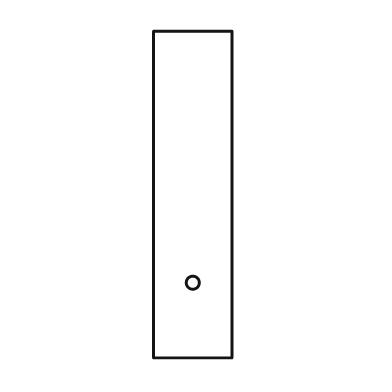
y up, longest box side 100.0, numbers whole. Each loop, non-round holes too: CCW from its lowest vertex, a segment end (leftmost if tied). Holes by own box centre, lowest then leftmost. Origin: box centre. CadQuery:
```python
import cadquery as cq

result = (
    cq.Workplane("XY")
    .moveTo(-12.0, -50.0)
    .lineTo(12.0, -50.0)
    .lineTo(12.0, 50.0)
    .lineTo(-12.0, 50.0)
    .close()
    .moveTo(0.0, -27.0)
    .circle(2.0)
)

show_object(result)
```